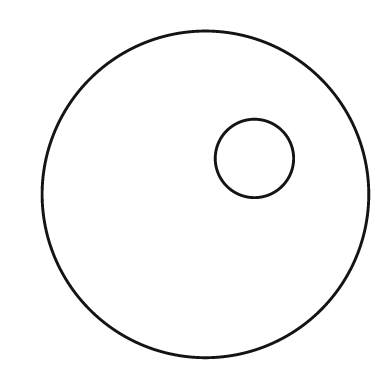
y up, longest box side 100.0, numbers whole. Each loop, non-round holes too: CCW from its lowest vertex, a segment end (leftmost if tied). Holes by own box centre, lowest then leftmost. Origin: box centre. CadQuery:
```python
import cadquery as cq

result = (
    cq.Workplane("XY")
    .moveTo(0.0, 0.0)
    .circle(50.0)
    .moveTo(15.0, 11.0)
    .circle(12.0)
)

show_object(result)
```